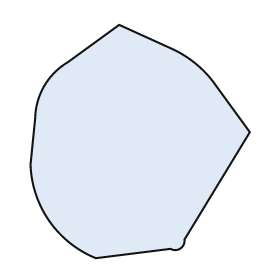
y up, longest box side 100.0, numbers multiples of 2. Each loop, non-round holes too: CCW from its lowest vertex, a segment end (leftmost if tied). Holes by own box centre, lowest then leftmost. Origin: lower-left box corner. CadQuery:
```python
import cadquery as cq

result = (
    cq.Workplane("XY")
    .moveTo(28.0, 0.0)
    .lineTo(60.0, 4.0)
    .threePointArc((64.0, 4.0), (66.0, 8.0))
    .lineTo(94.0, 54.0)
    .lineTo(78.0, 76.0)
    .threePointArc((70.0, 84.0), (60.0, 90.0))
    .lineTo(38.0, 100.0)
    .lineTo(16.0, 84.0)
    .threePointArc((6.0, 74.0), (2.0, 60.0))
    .lineTo(0.0, 40.0)
    .threePointArc((8.0, 16.0), (28.0, 0.0))
    .close()
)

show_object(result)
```